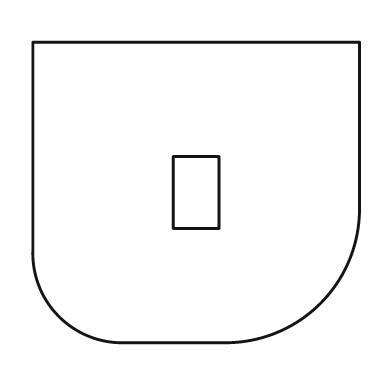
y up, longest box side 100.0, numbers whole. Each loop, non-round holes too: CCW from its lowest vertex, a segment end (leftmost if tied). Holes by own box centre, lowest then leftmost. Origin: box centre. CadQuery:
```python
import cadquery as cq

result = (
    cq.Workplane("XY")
    .moveTo(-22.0, -46.0)
    .lineTo(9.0, -46.0)
    .threePointArc((38.0, -34.0), (50.0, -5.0))
    .lineTo(50.0, 46.0)
    .lineTo(-50.0, 46.0)
    .lineTo(-50.0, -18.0)
    .threePointArc((-42.0, -38.0), (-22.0, -46.0))
    .close()
    .moveTo(-7.0, -11.0)
    .lineTo(7.0, -11.0)
    .lineTo(7.0, 11.0)
    .lineTo(-7.0, 11.0)
    .close()
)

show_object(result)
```